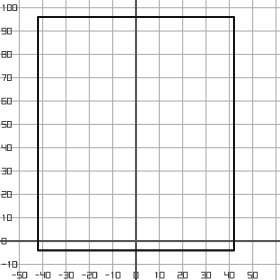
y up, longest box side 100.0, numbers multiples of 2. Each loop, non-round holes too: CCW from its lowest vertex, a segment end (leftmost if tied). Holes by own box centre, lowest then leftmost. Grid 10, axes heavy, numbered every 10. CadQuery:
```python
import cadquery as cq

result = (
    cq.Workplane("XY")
    .moveTo(-42.0, -4.0)
    .lineTo(42.0, -4.0)
    .lineTo(42.0, 96.0)
    .lineTo(-42.0, 96.0)
    .close()
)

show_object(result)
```